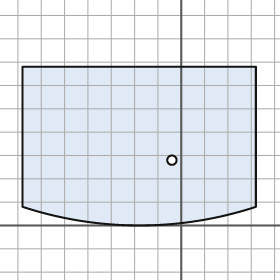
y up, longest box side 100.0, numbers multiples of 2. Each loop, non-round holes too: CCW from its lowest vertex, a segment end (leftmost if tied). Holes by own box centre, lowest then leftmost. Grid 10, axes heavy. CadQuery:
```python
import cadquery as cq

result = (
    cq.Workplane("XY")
    .moveTo(-68.0, 8.0)
    .threePointArc((-18.0, 0.0), (32.0, 8.0))
    .lineTo(32.0, 68.0)
    .lineTo(-68.0, 68.0)
    .close()
    .moveTo(-4.0, 28.0)
    .circle(2.0)
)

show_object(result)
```